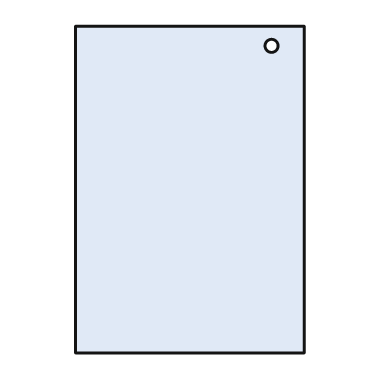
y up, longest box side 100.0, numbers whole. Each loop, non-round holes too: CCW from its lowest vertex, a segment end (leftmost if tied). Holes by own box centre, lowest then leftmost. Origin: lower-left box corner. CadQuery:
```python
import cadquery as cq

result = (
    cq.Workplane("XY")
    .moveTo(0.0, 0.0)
    .lineTo(70.0, 0.0)
    .lineTo(70.0, 100.0)
    .lineTo(0.0, 100.0)
    .close()
    .moveTo(60.0, 94.0)
    .circle(2.0)
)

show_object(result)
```